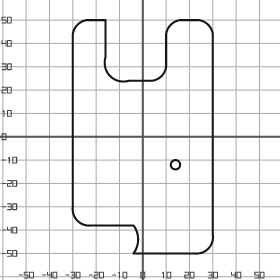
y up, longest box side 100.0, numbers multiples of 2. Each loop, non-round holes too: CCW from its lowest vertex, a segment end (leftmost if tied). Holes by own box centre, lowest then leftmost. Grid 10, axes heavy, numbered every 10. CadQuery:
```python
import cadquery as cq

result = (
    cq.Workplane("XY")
    .moveTo(-4.0, -50.0)
    .lineTo(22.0, -50.0)
    .threePointArc((28.0, -48.0), (30.0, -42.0))
    .lineTo(30.0, 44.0)
    .threePointArc((28.0, 48.0), (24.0, 50.0))
    .lineTo(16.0, 50.0)
    .threePointArc((12.0, 48.0), (10.0, 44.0))
    .lineTo(10.0, 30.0)
    .threePointArc((8.0, 26.0), (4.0, 24.0))
    .lineTo(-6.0, 24.0)
    .threePointArc((-14.0, 26.0), (-16.0, 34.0))
    .lineTo(-16.0, 50.0)
    .lineTo(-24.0, 50.0)
    .threePointArc((-28.0, 48.0), (-30.0, 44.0))
    .lineTo(-30.0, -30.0)
    .threePointArc((-28.0, -36.0), (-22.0, -38.0))
    .lineTo(-4.0, -38.0)
    .threePointArc((-2.0, -44.0), (-4.0, -50.0))
    .close()
    .moveTo(14.0, -12.0)
    .circle(2.0)
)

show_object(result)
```